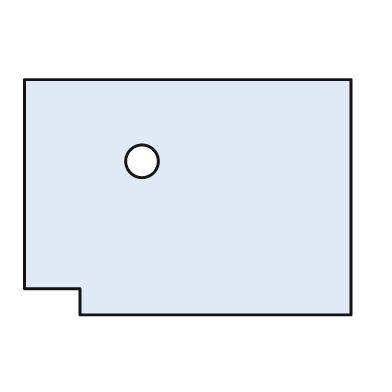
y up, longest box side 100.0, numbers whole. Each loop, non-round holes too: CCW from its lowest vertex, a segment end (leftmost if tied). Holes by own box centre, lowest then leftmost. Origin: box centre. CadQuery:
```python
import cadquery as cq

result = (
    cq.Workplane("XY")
    .moveTo(-33.0, -36.0)
    .lineTo(50.0, -36.0)
    .lineTo(50.0, 36.0)
    .lineTo(-50.0, 36.0)
    .lineTo(-50.0, -28.0)
    .lineTo(-33.0, -28.0)
    .close()
    .moveTo(-14.0, 11.0)
    .circle(5.0)
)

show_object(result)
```